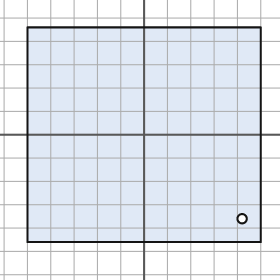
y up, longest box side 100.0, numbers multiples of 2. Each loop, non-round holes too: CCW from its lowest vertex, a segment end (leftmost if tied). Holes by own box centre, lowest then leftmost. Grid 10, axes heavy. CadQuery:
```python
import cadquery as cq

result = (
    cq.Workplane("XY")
    .moveTo(-50.0, -46.0)
    .lineTo(50.0, -46.0)
    .lineTo(50.0, 46.0)
    .lineTo(-50.0, 46.0)
    .close()
    .moveTo(42.0, -36.0)
    .circle(2.0)
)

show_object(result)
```